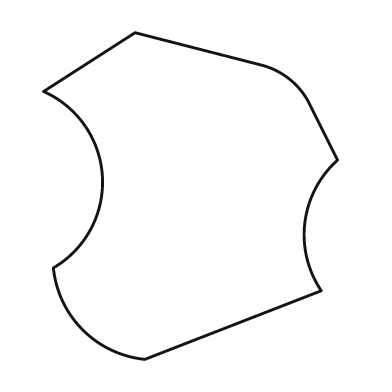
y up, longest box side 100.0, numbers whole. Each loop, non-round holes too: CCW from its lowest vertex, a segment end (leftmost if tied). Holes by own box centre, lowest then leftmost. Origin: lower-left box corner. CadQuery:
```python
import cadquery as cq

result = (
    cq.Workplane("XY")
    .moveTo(31.0, 0.0)
    .lineTo(85.0, 21.0)
    .threePointArc((80.0, 42.0), (90.0, 61.0))
    .lineTo(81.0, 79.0)
    .threePointArc((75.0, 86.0), (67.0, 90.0))
    .lineTo(28.0, 100.0)
    .lineTo(0.0, 82.0)
    .threePointArc((18.0, 56.0), (3.0, 28.0))
    .threePointArc((12.0, 9.0), (31.0, 0.0))
    .close()
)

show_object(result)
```